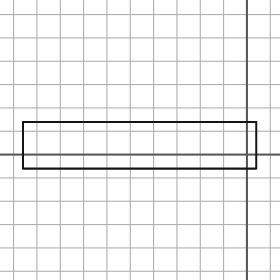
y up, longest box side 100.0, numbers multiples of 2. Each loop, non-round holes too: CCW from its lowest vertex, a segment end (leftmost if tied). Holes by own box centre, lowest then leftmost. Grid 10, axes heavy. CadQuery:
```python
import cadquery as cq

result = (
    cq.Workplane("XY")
    .moveTo(-96.0, -6.0)
    .lineTo(4.0, -6.0)
    .lineTo(4.0, 14.0)
    .lineTo(-96.0, 14.0)
    .close()
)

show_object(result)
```